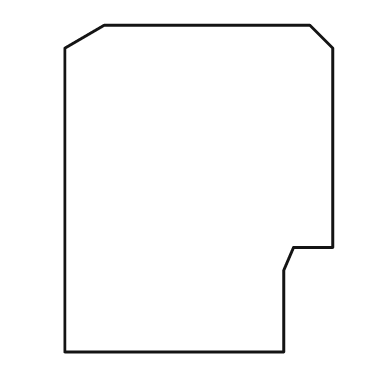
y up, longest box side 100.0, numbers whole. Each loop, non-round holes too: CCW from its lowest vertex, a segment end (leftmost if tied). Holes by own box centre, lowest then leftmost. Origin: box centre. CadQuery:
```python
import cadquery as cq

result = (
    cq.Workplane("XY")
    .moveTo(-41.0, -50.0)
    .lineTo(26.0, -50.0)
    .lineTo(26.0, -25.0)
    .lineTo(29.0, -18.0)
    .lineTo(41.0, -18.0)
    .lineTo(41.0, 43.0)
    .lineTo(34.0, 50.0)
    .lineTo(-29.0, 50.0)
    .lineTo(-41.0, 43.0)
    .close()
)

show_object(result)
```